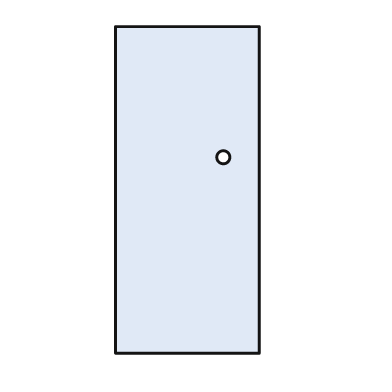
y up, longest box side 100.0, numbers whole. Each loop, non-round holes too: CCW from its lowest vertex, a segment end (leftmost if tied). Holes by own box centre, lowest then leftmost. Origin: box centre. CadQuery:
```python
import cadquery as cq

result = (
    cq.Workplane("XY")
    .moveTo(-22.0, -50.0)
    .lineTo(22.0, -50.0)
    .lineTo(22.0, 50.0)
    .lineTo(-22.0, 50.0)
    .close()
    .moveTo(11.0, 10.0)
    .circle(2.0)
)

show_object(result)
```